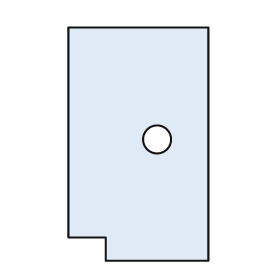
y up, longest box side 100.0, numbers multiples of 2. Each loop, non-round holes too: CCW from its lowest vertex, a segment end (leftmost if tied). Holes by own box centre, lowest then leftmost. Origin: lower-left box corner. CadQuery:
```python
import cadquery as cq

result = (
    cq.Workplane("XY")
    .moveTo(16.0, 0.0)
    .lineTo(60.0, 0.0)
    .lineTo(60.0, 100.0)
    .lineTo(0.0, 100.0)
    .lineTo(0.0, 10.0)
    .lineTo(16.0, 10.0)
    .close()
    .moveTo(38.0, 52.0)
    .circle(6.0)
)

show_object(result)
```